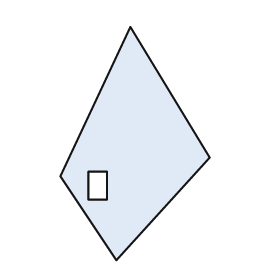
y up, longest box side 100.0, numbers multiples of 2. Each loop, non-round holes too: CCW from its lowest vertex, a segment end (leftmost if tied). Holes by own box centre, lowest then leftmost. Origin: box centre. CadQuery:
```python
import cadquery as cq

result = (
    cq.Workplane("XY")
    .moveTo(-8.0, -50.0)
    .lineTo(32.0, -6.0)
    .lineTo(-2.0, 50.0)
    .lineTo(-32.0, -14.0)
    .close()
    .moveTo(-20.0, -24.0)
    .lineTo(-12.0, -24.0)
    .lineTo(-12.0, -12.0)
    .lineTo(-20.0, -12.0)
    .close()
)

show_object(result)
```